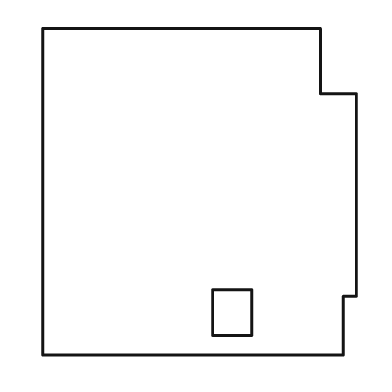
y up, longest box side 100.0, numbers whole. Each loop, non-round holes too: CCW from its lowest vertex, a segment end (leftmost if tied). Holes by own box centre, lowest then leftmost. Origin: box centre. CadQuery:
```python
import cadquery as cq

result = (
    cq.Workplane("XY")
    .moveTo(-48.0, -50.0)
    .lineTo(44.0, -50.0)
    .lineTo(44.0, -32.0)
    .lineTo(48.0, -32.0)
    .lineTo(48.0, 30.0)
    .lineTo(37.0, 30.0)
    .lineTo(37.0, 50.0)
    .lineTo(-48.0, 50.0)
    .close()
    .moveTo(4.0, -44.0)
    .lineTo(16.0, -44.0)
    .lineTo(16.0, -30.0)
    .lineTo(4.0, -30.0)
    .close()
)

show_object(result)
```